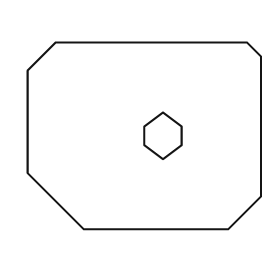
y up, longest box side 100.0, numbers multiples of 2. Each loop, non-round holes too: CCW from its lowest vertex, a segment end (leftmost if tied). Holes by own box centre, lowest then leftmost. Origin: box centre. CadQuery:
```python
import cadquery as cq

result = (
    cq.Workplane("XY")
    .moveTo(-26.0, -40.0)
    .lineTo(36.0, -40.0)
    .lineTo(50.0, -26.0)
    .lineTo(50.0, 34.0)
    .lineTo(44.0, 40.0)
    .lineTo(-38.0, 40.0)
    .lineTo(-50.0, 28.0)
    .lineTo(-50.0, -16.0)
    .close()
    .moveTo(8.0, -10.0)
    .lineTo(16.0, -4.0)
    .lineTo(16.0, 4.0)
    .lineTo(8.0, 10.0)
    .lineTo(0.0, 4.0)
    .lineTo(0.0, -4.0)
    .close()
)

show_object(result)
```